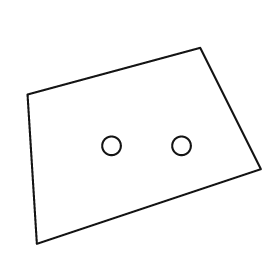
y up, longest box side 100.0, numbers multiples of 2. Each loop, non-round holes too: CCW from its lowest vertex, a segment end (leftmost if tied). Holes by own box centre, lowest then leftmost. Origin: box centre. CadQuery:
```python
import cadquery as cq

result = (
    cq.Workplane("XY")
    .moveTo(-46.0, -42.0)
    .lineTo(50.0, -10.0)
    .lineTo(24.0, 42.0)
    .lineTo(-50.0, 22.0)
    .close()
    .moveTo(-14.0, 0.0)
    .circle(4.0)
    .moveTo(16.0, 0.0)
    .circle(4.0)
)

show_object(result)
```